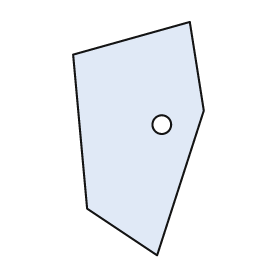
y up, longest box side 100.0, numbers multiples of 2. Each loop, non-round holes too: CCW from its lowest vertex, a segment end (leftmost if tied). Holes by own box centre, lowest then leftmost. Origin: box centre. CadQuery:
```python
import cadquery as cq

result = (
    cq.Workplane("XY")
    .moveTo(8.0, -50.0)
    .lineTo(28.0, 12.0)
    .lineTo(22.0, 50.0)
    .lineTo(-28.0, 36.0)
    .lineTo(-22.0, -30.0)
    .close()
    .moveTo(10.0, 6.0)
    .circle(4.0)
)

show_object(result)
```